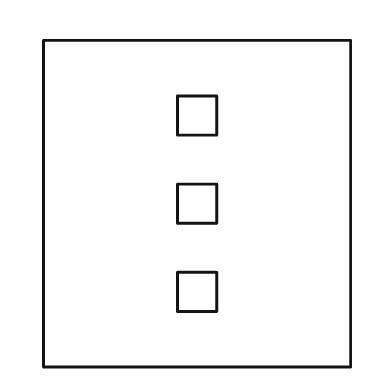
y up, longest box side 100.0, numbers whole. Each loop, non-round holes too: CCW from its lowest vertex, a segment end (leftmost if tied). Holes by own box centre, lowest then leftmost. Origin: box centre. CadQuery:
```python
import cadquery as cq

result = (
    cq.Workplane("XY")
    .moveTo(-47.0, -50.0)
    .lineTo(47.0, -50.0)
    .lineTo(47.0, 50.0)
    .lineTo(-47.0, 50.0)
    .close()
    .moveTo(-6.0, -33.0)
    .lineTo(6.0, -33.0)
    .lineTo(6.0, -21.0)
    .lineTo(-6.0, -21.0)
    .close()
    .moveTo(-6.0, -6.0)
    .lineTo(6.0, -6.0)
    .lineTo(6.0, 6.0)
    .lineTo(-6.0, 6.0)
    .close()
    .moveTo(-6.0, 21.0)
    .lineTo(6.0, 21.0)
    .lineTo(6.0, 33.0)
    .lineTo(-6.0, 33.0)
    .close()
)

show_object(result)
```